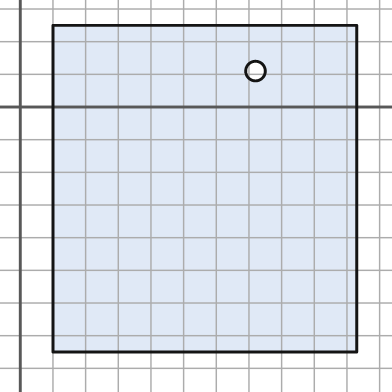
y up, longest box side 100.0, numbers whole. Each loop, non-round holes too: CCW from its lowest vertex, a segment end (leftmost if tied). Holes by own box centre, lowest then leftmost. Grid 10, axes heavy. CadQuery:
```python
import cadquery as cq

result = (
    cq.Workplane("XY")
    .moveTo(10.0, -75.0)
    .lineTo(103.0, -75.0)
    .lineTo(103.0, 25.0)
    .lineTo(10.0, 25.0)
    .close()
    .moveTo(72.0, 11.0)
    .circle(3.0)
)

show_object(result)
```